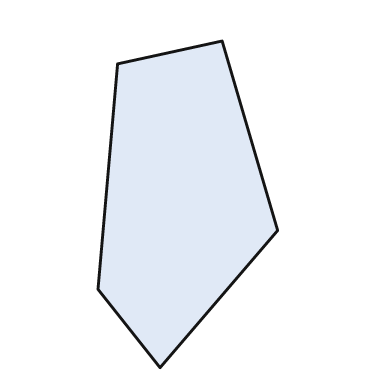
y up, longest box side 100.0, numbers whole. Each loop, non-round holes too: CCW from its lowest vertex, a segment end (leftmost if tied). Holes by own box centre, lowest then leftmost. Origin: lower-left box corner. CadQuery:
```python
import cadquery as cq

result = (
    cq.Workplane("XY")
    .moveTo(19.0, 0.0)
    .lineTo(55.0, 42.0)
    .lineTo(38.0, 100.0)
    .lineTo(6.0, 93.0)
    .lineTo(0.0, 24.0)
    .close()
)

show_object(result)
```